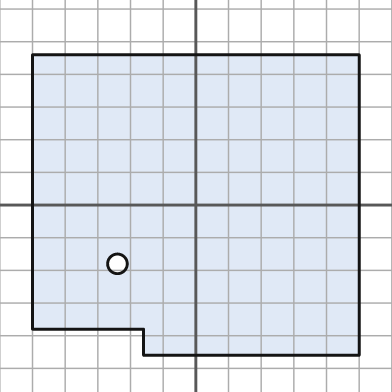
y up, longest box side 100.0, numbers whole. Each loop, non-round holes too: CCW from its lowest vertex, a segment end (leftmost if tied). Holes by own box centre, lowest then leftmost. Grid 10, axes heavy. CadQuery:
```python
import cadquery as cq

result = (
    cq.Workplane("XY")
    .moveTo(-16.0, -46.0)
    .lineTo(50.0, -46.0)
    .lineTo(50.0, 46.0)
    .lineTo(-50.0, 46.0)
    .lineTo(-50.0, -38.0)
    .lineTo(-16.0, -38.0)
    .close()
    .moveTo(-24.0, -18.0)
    .circle(3.0)
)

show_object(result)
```